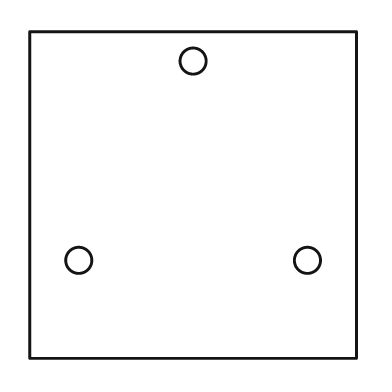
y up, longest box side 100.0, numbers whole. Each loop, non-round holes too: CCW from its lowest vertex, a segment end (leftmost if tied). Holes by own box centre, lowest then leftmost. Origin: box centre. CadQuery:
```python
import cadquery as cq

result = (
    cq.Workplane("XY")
    .moveTo(-50.0, -50.0)
    .lineTo(50.0, -50.0)
    .lineTo(50.0, 50.0)
    .lineTo(-50.0, 50.0)
    .close()
    .moveTo(-35.0, -20.0)
    .circle(4.0)
    .moveTo(35.0, -20.0)
    .circle(4.0)
    .moveTo(0.0, 41.0)
    .circle(4.0)
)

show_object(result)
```